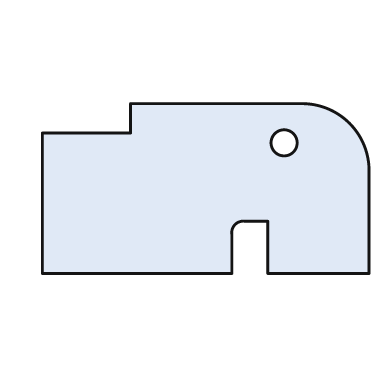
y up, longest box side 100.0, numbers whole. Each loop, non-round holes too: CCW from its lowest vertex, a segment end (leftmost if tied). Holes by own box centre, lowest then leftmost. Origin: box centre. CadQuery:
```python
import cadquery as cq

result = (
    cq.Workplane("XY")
    .moveTo(-50.0, -26.0)
    .lineTo(8.0, -26.0)
    .lineTo(8.0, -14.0)
    .threePointArc((9.0, -11.0), (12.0, -10.0))
    .lineTo(19.0, -10.0)
    .lineTo(19.0, -26.0)
    .lineTo(50.0, -26.0)
    .lineTo(50.0, 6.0)
    .threePointArc((44.0, 20.0), (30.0, 26.0))
    .lineTo(-23.0, 26.0)
    .lineTo(-23.0, 17.0)
    .lineTo(-50.0, 17.0)
    .close()
    .moveTo(24.0, 14.0)
    .circle(4.0)
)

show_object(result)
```